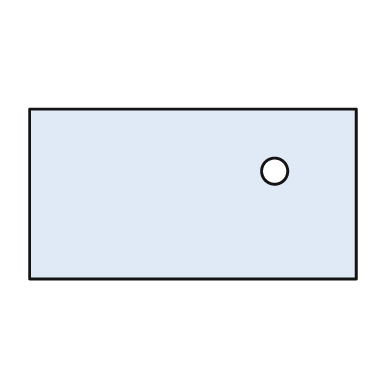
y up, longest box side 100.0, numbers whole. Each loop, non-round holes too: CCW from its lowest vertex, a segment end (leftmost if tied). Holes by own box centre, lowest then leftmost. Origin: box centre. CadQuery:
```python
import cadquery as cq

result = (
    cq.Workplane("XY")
    .moveTo(-50.0, -26.0)
    .lineTo(50.0, -26.0)
    .lineTo(50.0, 26.0)
    .lineTo(-50.0, 26.0)
    .close()
    .moveTo(25.0, 7.0)
    .circle(4.0)
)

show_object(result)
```